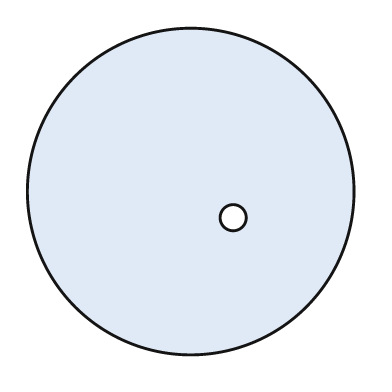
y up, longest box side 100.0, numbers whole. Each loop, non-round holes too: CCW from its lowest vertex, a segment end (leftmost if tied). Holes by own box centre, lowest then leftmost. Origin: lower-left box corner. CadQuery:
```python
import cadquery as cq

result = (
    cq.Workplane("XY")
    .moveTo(50.0, 50.0)
    .circle(50.0)
    .moveTo(63.0, 42.0)
    .circle(4.0)
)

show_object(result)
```